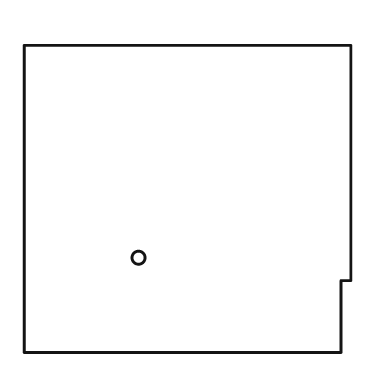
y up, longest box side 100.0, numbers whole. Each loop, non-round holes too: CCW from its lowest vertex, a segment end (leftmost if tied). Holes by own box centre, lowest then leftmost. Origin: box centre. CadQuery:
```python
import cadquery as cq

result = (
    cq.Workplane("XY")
    .moveTo(-50.0, -47.0)
    .lineTo(47.0, -47.0)
    .lineTo(47.0, -25.0)
    .lineTo(50.0, -25.0)
    .lineTo(50.0, 47.0)
    .lineTo(-50.0, 47.0)
    .close()
    .moveTo(-15.0, -18.0)
    .circle(2.0)
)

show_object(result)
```